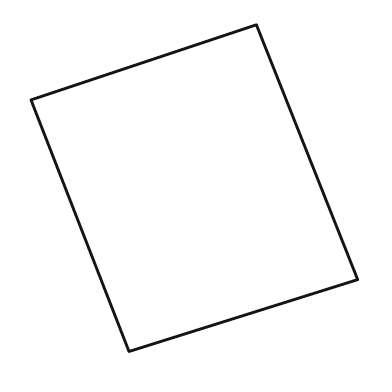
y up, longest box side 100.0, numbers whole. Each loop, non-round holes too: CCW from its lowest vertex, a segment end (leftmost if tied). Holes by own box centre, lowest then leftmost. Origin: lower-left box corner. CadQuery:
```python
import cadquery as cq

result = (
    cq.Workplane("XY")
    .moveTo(30.0, 0.0)
    .lineTo(100.0, 22.0)
    .lineTo(69.0, 100.0)
    .lineTo(0.0, 77.0)
    .close()
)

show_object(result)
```